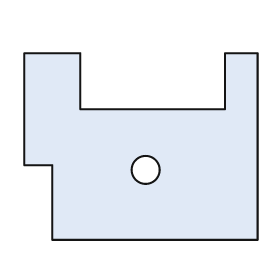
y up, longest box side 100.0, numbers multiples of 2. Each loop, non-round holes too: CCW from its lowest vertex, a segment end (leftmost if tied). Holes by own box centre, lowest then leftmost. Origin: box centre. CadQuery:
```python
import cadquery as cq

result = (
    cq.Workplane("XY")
    .moveTo(-38.0, -40.0)
    .lineTo(50.0, -40.0)
    .lineTo(50.0, 40.0)
    .lineTo(36.0, 40.0)
    .lineTo(36.0, 16.0)
    .lineTo(-26.0, 16.0)
    .lineTo(-26.0, 40.0)
    .lineTo(-50.0, 40.0)
    .lineTo(-50.0, -8.0)
    .lineTo(-38.0, -8.0)
    .close()
    .moveTo(2.0, -10.0)
    .circle(6.0)
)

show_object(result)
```